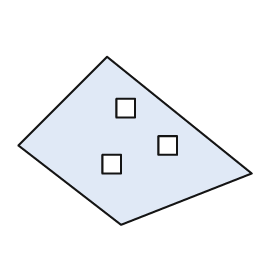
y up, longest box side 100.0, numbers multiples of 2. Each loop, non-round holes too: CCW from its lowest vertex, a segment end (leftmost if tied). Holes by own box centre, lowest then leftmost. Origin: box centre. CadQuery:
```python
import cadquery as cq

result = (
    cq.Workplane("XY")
    .moveTo(-6.0, -36.0)
    .lineTo(50.0, -14.0)
    .lineTo(-12.0, 36.0)
    .lineTo(-50.0, -2.0)
    .close()
    .moveTo(-14.0, -14.0)
    .lineTo(-6.0, -14.0)
    .lineTo(-6.0, -6.0)
    .lineTo(-14.0, -6.0)
    .close()
    .moveTo(10.0, -6.0)
    .lineTo(18.0, -6.0)
    .lineTo(18.0, 2.0)
    .lineTo(10.0, 2.0)
    .close()
    .moveTo(-8.0, 10.0)
    .lineTo(0.0, 10.0)
    .lineTo(0.0, 18.0)
    .lineTo(-8.0, 18.0)
    .close()
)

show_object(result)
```